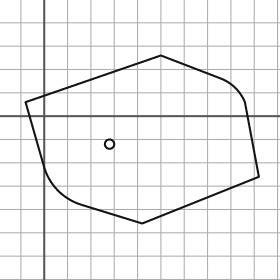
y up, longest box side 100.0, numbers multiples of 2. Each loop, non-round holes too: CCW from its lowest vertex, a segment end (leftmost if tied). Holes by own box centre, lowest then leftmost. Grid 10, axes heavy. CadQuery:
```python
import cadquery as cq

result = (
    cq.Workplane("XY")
    .moveTo(42.0, -46.0)
    .lineTo(92.0, -26.0)
    .lineTo(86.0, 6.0)
    .threePointArc((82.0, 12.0), (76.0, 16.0))
    .lineTo(50.0, 26.0)
    .lineTo(-8.0, 6.0)
    .lineTo(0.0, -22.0)
    .threePointArc((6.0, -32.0), (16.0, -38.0))
    .close()
    .moveTo(28.0, -12.0)
    .circle(2.0)
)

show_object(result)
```